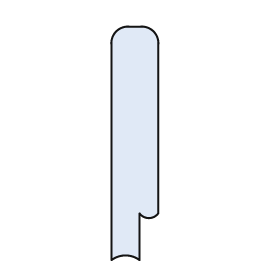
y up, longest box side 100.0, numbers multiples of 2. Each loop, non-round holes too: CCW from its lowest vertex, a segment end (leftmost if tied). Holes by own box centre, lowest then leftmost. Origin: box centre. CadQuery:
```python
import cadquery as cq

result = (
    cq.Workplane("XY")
    .moveTo(-10.0, -50.0)
    .threePointArc((-4.0, -48.0), (2.0, -50.0))
    .lineTo(2.0, -30.0)
    .threePointArc((6.0, -32.0), (10.0, -30.0))
    .lineTo(10.0, 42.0)
    .threePointArc((8.0, 48.0), (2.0, 50.0))
    .lineTo(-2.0, 50.0)
    .threePointArc((-8.0, 48.0), (-10.0, 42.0))
    .close()
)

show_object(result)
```